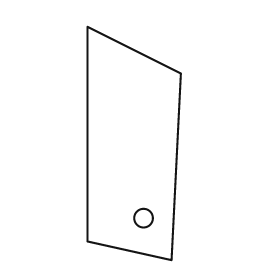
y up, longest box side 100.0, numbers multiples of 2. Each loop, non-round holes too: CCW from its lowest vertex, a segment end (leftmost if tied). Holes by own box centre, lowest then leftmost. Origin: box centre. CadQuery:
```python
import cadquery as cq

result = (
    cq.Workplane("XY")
    .moveTo(16.0, -50.0)
    .lineTo(20.0, 30.0)
    .lineTo(-20.0, 50.0)
    .lineTo(-20.0, -42.0)
    .close()
    .moveTo(4.0, -32.0)
    .circle(4.0)
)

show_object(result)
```